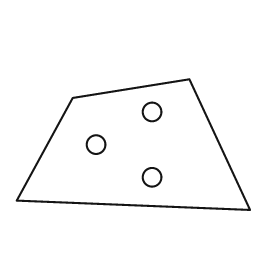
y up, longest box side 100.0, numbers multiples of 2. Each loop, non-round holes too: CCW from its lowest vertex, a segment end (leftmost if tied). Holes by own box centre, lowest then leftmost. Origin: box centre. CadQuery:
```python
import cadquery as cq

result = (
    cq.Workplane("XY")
    .moveTo(50.0, -28.0)
    .lineTo(24.0, 28.0)
    .lineTo(-26.0, 20.0)
    .lineTo(-50.0, -24.0)
    .close()
    .moveTo(8.0, -14.0)
    .circle(4.0)
    .moveTo(-16.0, 0.0)
    .circle(4.0)
    .moveTo(8.0, 14.0)
    .circle(4.0)
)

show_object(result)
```